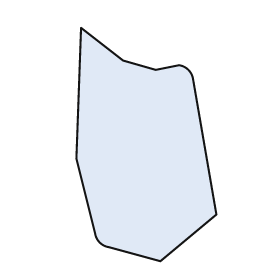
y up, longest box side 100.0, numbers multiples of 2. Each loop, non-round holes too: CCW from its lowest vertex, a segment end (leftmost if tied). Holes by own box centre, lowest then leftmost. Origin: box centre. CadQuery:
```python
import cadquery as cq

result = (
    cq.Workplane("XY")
    .moveTo(6.0, -50.0)
    .lineTo(30.0, -30.0)
    .lineTo(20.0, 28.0)
    .threePointArc((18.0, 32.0), (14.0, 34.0))
    .lineTo(4.0, 32.0)
    .lineTo(-10.0, 36.0)
    .lineTo(-28.0, 50.0)
    .lineTo(-30.0, -6.0)
    .lineTo(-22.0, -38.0)
    .threePointArc((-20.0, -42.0), (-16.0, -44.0))
    .close()
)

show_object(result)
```